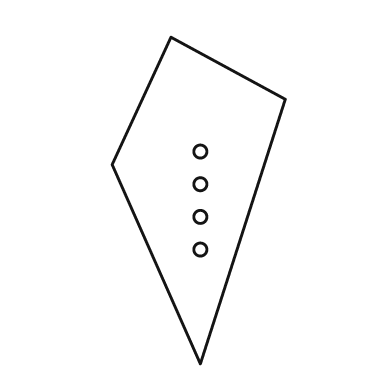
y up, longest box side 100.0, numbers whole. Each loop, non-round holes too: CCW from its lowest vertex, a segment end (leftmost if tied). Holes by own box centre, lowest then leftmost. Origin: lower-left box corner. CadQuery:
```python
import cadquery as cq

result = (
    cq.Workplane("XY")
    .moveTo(27.0, 0.0)
    .lineTo(53.0, 81.0)
    .lineTo(18.0, 100.0)
    .lineTo(0.0, 61.0)
    .close()
    .moveTo(27.0, 35.0)
    .circle(2.0)
    .moveTo(27.0, 45.0)
    .circle(2.0)
    .moveTo(27.0, 55.0)
    .circle(2.0)
    .moveTo(27.0, 65.0)
    .circle(2.0)
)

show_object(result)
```